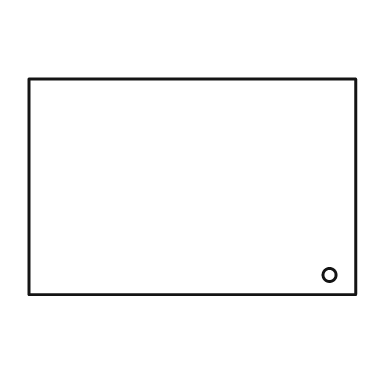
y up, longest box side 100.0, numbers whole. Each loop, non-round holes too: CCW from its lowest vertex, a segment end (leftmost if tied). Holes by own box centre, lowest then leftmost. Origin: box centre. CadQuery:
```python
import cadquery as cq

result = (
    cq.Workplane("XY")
    .moveTo(-50.0, -33.0)
    .lineTo(50.0, -33.0)
    .lineTo(50.0, 33.0)
    .lineTo(-50.0, 33.0)
    .close()
    .moveTo(42.0, -27.0)
    .circle(2.0)
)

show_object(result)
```